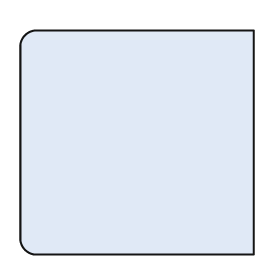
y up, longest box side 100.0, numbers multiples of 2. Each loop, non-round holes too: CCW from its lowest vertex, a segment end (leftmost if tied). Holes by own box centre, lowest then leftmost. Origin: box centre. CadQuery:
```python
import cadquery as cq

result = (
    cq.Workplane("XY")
    .moveTo(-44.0, -48.0)
    .lineTo(50.0, -48.0)
    .lineTo(50.0, 48.0)
    .lineTo(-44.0, 48.0)
    .threePointArc((-48.0, 46.0), (-50.0, 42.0))
    .lineTo(-50.0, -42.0)
    .threePointArc((-48.0, -46.0), (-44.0, -48.0))
    .close()
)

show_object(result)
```